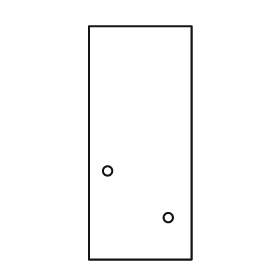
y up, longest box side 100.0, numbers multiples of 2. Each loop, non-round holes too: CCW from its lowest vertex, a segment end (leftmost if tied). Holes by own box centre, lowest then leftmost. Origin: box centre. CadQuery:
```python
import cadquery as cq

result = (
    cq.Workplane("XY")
    .moveTo(-22.0, -50.0)
    .lineTo(22.0, -50.0)
    .lineTo(22.0, 50.0)
    .lineTo(-22.0, 50.0)
    .close()
    .moveTo(12.0, -32.0)
    .circle(2.0)
    .moveTo(-14.0, -12.0)
    .circle(2.0)
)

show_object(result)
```